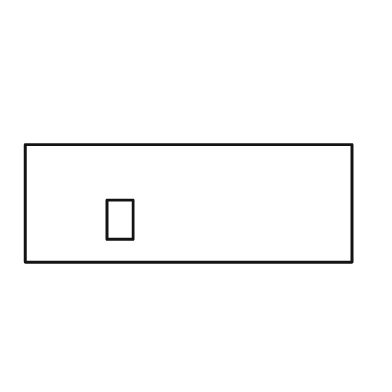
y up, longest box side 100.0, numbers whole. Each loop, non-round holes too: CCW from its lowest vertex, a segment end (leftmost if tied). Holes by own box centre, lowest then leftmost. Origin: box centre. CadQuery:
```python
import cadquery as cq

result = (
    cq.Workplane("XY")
    .moveTo(-50.0, -18.0)
    .lineTo(50.0, -18.0)
    .lineTo(50.0, 18.0)
    .lineTo(-50.0, 18.0)
    .close()
    .moveTo(-25.0, -11.0)
    .lineTo(-17.0, -11.0)
    .lineTo(-17.0, 1.0)
    .lineTo(-25.0, 1.0)
    .close()
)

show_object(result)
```